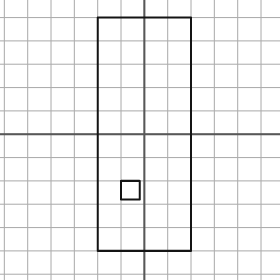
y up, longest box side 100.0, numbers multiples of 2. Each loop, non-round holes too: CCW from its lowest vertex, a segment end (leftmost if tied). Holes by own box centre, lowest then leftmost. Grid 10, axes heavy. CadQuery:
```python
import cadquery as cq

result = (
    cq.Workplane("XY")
    .moveTo(-20.0, -50.0)
    .lineTo(20.0, -50.0)
    .lineTo(20.0, 50.0)
    .lineTo(-20.0, 50.0)
    .close()
    .moveTo(-10.0, -28.0)
    .lineTo(-2.0, -28.0)
    .lineTo(-2.0, -20.0)
    .lineTo(-10.0, -20.0)
    .close()
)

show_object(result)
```